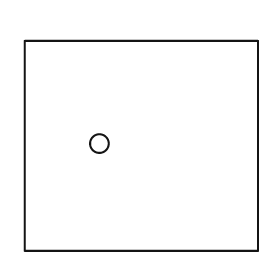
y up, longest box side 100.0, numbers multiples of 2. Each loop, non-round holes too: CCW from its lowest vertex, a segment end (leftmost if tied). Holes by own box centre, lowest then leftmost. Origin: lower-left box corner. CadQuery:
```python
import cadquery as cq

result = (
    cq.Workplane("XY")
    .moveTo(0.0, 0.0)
    .lineTo(100.0, 0.0)
    .lineTo(100.0, 90.0)
    .lineTo(0.0, 90.0)
    .close()
    .moveTo(32.0, 46.0)
    .circle(4.0)
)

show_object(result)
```